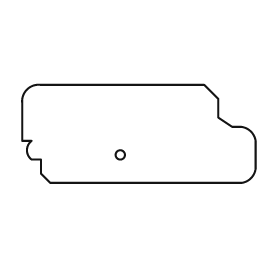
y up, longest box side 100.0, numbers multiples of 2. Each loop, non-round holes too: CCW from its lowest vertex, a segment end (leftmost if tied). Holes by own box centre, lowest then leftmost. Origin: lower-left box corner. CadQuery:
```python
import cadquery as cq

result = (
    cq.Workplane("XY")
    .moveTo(12.0, 0.0)
    .lineTo(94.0, 0.0)
    .threePointArc((98.0, 2.0), (100.0, 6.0))
    .lineTo(100.0, 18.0)
    .threePointArc((98.0, 22.0), (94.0, 24.0))
    .lineTo(90.0, 24.0)
    .lineTo(84.0, 28.0)
    .lineTo(84.0, 36.0)
    .lineTo(78.0, 42.0)
    .lineTo(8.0, 42.0)
    .threePointArc((2.0, 40.0), (0.0, 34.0))
    .lineTo(0.0, 18.0)
    .lineTo(4.0, 18.0)
    .threePointArc((2.0, 14.0), (4.0, 10.0))
    .lineTo(8.0, 10.0)
    .lineTo(8.0, 4.0)
    .close()
    .moveTo(42.0, 12.0)
    .circle(2.0)
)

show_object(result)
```